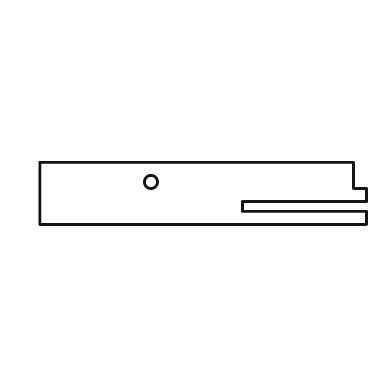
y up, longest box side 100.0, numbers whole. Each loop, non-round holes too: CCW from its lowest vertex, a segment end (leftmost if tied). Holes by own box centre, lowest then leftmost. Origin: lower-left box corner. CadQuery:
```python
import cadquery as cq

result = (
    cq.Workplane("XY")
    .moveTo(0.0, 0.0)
    .lineTo(100.0, 0.0)
    .lineTo(100.0, 4.0)
    .lineTo(62.0, 4.0)
    .lineTo(62.0, 7.0)
    .lineTo(100.0, 7.0)
    .lineTo(100.0, 11.0)
    .lineTo(96.0, 11.0)
    .lineTo(96.0, 19.0)
    .lineTo(0.0, 19.0)
    .close()
    .moveTo(34.0, 13.0)
    .circle(2.0)
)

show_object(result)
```